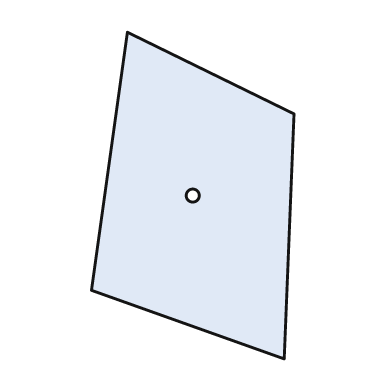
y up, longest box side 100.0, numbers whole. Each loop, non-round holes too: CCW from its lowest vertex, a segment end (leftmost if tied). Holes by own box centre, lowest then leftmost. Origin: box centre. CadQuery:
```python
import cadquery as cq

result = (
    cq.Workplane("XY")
    .moveTo(28.0, -50.0)
    .lineTo(31.0, 25.0)
    .lineTo(-20.0, 50.0)
    .lineTo(-31.0, -29.0)
    .close()
    .moveTo(0.0, 0.0)
    .circle(2.0)
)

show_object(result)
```